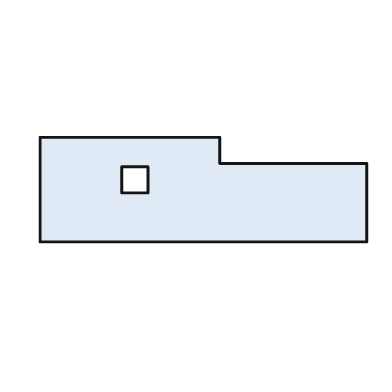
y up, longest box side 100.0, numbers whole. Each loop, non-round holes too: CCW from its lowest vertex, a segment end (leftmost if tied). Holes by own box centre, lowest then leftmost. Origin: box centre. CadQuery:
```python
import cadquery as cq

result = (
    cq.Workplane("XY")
    .moveTo(-50.0, -16.0)
    .lineTo(50.0, -16.0)
    .lineTo(50.0, 8.0)
    .lineTo(5.0, 8.0)
    .lineTo(5.0, 16.0)
    .lineTo(-50.0, 16.0)
    .close()
    .moveTo(-25.0, -1.0)
    .lineTo(-17.0, -1.0)
    .lineTo(-17.0, 7.0)
    .lineTo(-25.0, 7.0)
    .close()
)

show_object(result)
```